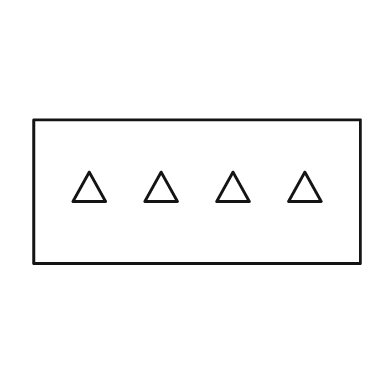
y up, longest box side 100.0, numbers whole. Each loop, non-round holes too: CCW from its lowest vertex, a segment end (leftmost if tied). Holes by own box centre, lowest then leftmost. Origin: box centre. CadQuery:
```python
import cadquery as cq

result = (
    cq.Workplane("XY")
    .moveTo(-50.0, -22.0)
    .lineTo(50.0, -22.0)
    .lineTo(50.0, 22.0)
    .lineTo(-50.0, 22.0)
    .close()
    .moveTo(-38.0, -3.0)
    .lineTo(-28.0, -3.0)
    .lineTo(-33.0, 6.0)
    .close()
    .moveTo(-16.0, -3.0)
    .lineTo(-6.0, -3.0)
    .lineTo(-11.0, 6.0)
    .close()
    .moveTo(6.0, -3.0)
    .lineTo(16.0, -3.0)
    .lineTo(11.0, 6.0)
    .close()
    .moveTo(28.0, -3.0)
    .lineTo(38.0, -3.0)
    .lineTo(33.0, 6.0)
    .close()
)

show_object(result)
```